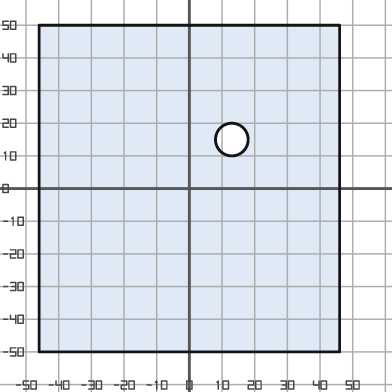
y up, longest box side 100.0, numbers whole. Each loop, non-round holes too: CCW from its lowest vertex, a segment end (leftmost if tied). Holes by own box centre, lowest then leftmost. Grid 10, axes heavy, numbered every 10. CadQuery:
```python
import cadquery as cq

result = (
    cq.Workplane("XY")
    .moveTo(-46.0, -50.0)
    .lineTo(46.0, -50.0)
    .lineTo(46.0, 50.0)
    .lineTo(-46.0, 50.0)
    .close()
    .moveTo(13.0, 15.0)
    .circle(5.0)
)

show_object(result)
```